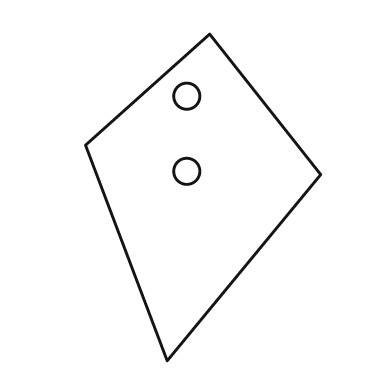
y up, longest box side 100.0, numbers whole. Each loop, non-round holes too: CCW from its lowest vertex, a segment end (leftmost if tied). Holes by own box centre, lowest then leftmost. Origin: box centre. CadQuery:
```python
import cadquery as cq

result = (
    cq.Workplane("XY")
    .moveTo(-11.0, -50.0)
    .lineTo(36.0, 7.0)
    .lineTo(2.0, 50.0)
    .lineTo(-36.0, 16.0)
    .close()
    .moveTo(-5.0, 8.0)
    .circle(4.0)
    .moveTo(-5.0, 31.0)
    .circle(4.0)
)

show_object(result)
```